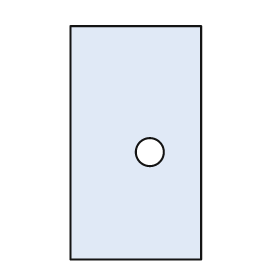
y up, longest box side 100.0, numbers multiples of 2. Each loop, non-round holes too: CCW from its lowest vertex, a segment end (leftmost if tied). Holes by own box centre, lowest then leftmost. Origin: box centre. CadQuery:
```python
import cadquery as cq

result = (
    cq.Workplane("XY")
    .moveTo(-28.0, -50.0)
    .lineTo(28.0, -50.0)
    .lineTo(28.0, 50.0)
    .lineTo(-28.0, 50.0)
    .close()
    .moveTo(6.0, -4.0)
    .circle(6.0)
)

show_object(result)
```